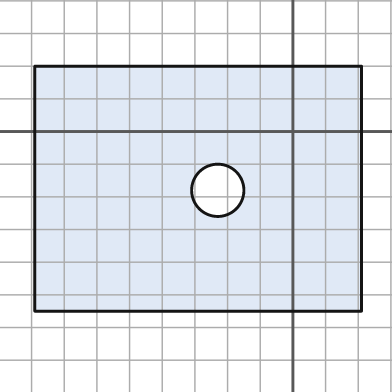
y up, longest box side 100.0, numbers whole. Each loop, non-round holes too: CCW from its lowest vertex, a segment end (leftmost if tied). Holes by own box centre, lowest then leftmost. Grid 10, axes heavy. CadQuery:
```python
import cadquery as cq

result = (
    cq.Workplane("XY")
    .moveTo(-79.0, -55.0)
    .lineTo(21.0, -55.0)
    .lineTo(21.0, 20.0)
    .lineTo(-79.0, 20.0)
    .close()
    .moveTo(-23.0, -18.0)
    .circle(8.0)
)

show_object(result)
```